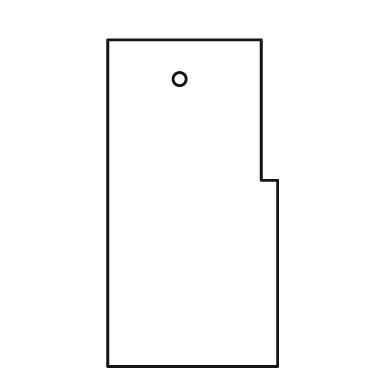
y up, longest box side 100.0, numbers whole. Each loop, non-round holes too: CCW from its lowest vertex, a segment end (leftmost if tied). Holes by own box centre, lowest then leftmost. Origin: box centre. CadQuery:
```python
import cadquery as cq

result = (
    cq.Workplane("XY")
    .moveTo(-26.0, -50.0)
    .lineTo(26.0, -50.0)
    .lineTo(26.0, 7.0)
    .lineTo(21.0, 7.0)
    .lineTo(21.0, 50.0)
    .lineTo(-26.0, 50.0)
    .close()
    .moveTo(-4.0, 38.0)
    .circle(2.0)
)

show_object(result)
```